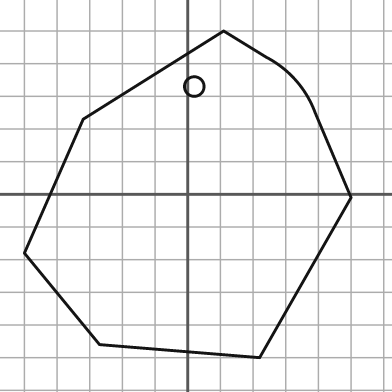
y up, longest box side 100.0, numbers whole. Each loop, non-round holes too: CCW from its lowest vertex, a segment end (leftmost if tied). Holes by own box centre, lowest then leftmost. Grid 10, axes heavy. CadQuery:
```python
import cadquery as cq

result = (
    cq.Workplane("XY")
    .moveTo(22.0, -50.0)
    .lineTo(50.0, -1.0)
    .lineTo(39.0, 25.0)
    .threePointArc((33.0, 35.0), (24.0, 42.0))
    .lineTo(11.0, 50.0)
    .lineTo(-32.0, 23.0)
    .lineTo(-50.0, -18.0)
    .lineTo(-27.0, -46.0)
    .close()
    .moveTo(2.0, 33.0)
    .circle(3.0)
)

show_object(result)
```